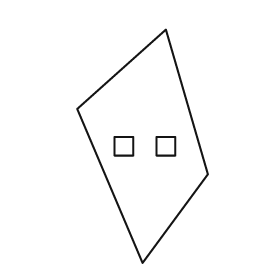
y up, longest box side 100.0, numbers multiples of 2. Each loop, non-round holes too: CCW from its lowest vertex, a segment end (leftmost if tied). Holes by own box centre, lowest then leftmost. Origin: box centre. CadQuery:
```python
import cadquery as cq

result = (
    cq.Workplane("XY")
    .moveTo(0.0, -50.0)
    .lineTo(28.0, -12.0)
    .lineTo(10.0, 50.0)
    .lineTo(-28.0, 16.0)
    .close()
    .moveTo(-12.0, -4.0)
    .lineTo(-4.0, -4.0)
    .lineTo(-4.0, 4.0)
    .lineTo(-12.0, 4.0)
    .close()
    .moveTo(6.0, -4.0)
    .lineTo(14.0, -4.0)
    .lineTo(14.0, 4.0)
    .lineTo(6.0, 4.0)
    .close()
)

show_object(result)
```